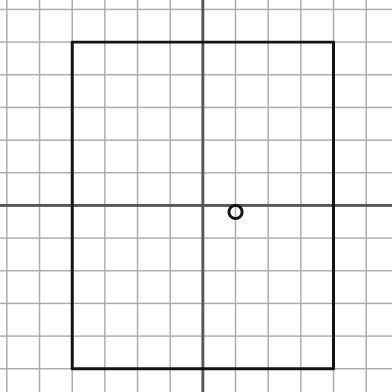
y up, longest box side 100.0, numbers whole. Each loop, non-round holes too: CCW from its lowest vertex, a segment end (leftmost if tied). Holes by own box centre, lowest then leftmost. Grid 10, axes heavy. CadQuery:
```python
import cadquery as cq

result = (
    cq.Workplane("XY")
    .moveTo(-40.0, -50.0)
    .lineTo(40.0, -50.0)
    .lineTo(40.0, 50.0)
    .lineTo(-40.0, 50.0)
    .close()
    .moveTo(10.0, -2.0)
    .circle(2.0)
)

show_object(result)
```